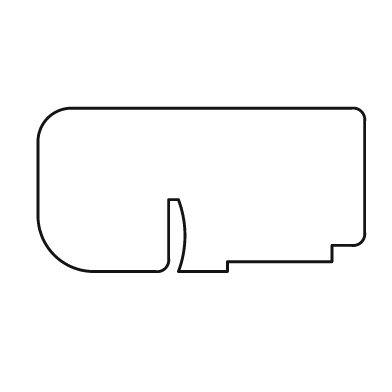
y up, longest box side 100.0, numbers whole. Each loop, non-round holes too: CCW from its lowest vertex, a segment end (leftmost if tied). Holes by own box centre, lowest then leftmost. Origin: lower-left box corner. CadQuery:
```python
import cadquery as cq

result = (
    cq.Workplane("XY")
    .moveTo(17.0, 0.0)
    .lineTo(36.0, 0.0)
    .threePointArc((39.0, 1.0), (40.0, 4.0))
    .lineTo(40.0, 22.0)
    .lineTo(43.0, 22.0)
    .threePointArc((45.0, 11.0), (43.0, 0.0))
    .lineTo(58.0, 0.0)
    .lineTo(58.0, 3.0)
    .lineTo(90.0, 3.0)
    .lineTo(90.0, 8.0)
    .lineTo(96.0, 8.0)
    .threePointArc((99.0, 9.0), (100.0, 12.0))
    .lineTo(100.0, 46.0)
    .threePointArc((99.0, 49.0), (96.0, 50.0))
    .lineTo(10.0, 50.0)
    .threePointArc((3.0, 47.0), (0.0, 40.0))
    .lineTo(0.0, 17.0)
    .threePointArc((5.0, 5.0), (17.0, 0.0))
    .close()
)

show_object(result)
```